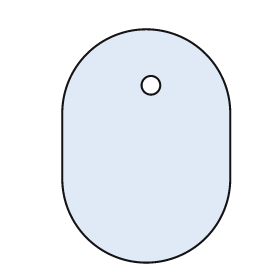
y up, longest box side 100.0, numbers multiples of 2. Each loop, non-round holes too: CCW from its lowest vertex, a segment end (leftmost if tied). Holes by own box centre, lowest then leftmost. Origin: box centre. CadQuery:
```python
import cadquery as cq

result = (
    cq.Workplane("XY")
    .moveTo(-36.0, -14.0)
    .threePointArc((0.0, -50.0), (36.0, -14.0))
    .lineTo(36.0, 14.0)
    .threePointArc((0.0, 50.0), (-36.0, 14.0))
    .close()
    .moveTo(2.0, 26.0)
    .circle(4.0)
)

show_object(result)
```